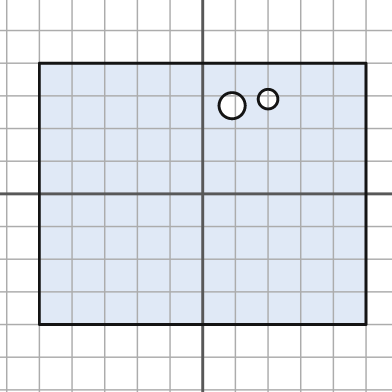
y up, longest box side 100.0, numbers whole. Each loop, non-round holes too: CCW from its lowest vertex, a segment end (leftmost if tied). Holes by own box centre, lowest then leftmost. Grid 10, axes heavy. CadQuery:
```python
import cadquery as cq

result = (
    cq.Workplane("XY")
    .moveTo(-50.0, -40.0)
    .lineTo(50.0, -40.0)
    .lineTo(50.0, 40.0)
    .lineTo(-50.0, 40.0)
    .close()
    .moveTo(9.0, 27.0)
    .circle(4.0)
    .moveTo(20.0, 29.0)
    .circle(3.0)
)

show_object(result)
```